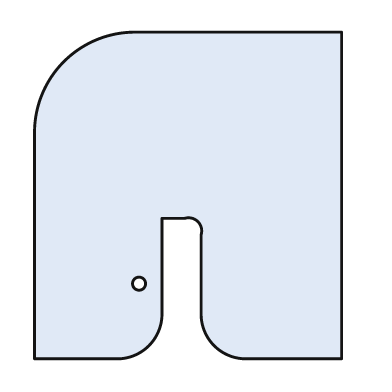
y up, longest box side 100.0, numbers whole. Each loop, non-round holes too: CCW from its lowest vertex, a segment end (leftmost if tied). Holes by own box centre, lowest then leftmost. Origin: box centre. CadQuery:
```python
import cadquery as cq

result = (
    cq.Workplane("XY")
    .moveTo(-47.0, -50.0)
    .lineTo(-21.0, -50.0)
    .threePointArc((-12.0, -46.0), (-8.0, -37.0))
    .lineTo(-8.0, -7.0)
    .lineTo(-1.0, -7.0)
    .threePointArc((3.0, -8.0), (4.0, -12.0))
    .lineTo(4.0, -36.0)
    .threePointArc((8.0, -46.0), (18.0, -50.0))
    .lineTo(47.0, -50.0)
    .lineTo(47.0, 50.0)
    .lineTo(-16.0, 50.0)
    .threePointArc((-38.0, 41.0), (-47.0, 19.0))
    .close()
    .moveTo(-15.0, -27.0)
    .circle(2.0)
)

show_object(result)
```